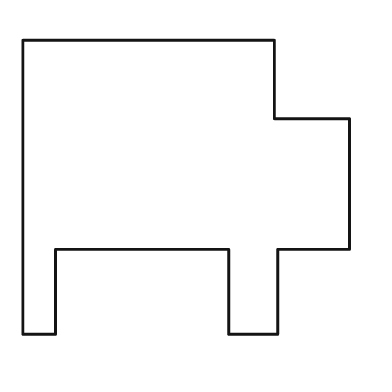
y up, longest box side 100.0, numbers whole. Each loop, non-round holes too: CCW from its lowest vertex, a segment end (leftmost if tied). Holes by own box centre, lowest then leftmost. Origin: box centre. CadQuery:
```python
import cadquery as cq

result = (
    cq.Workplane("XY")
    .moveTo(-50.0, -45.0)
    .lineTo(-40.0, -45.0)
    .lineTo(-40.0, -19.0)
    .lineTo(13.0, -19.0)
    .lineTo(13.0, -45.0)
    .lineTo(28.0, -45.0)
    .lineTo(28.0, -19.0)
    .lineTo(50.0, -19.0)
    .lineTo(50.0, 21.0)
    .lineTo(27.0, 21.0)
    .lineTo(27.0, 45.0)
    .lineTo(-50.0, 45.0)
    .close()
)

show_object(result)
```